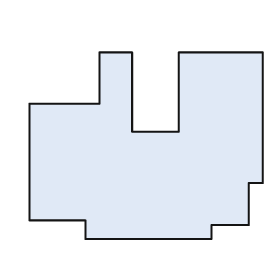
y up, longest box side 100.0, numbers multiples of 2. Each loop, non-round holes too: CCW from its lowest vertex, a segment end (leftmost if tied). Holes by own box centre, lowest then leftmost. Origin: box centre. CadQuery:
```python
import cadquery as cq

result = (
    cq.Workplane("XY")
    .moveTo(-26.0, -40.0)
    .lineTo(28.0, -40.0)
    .lineTo(28.0, -34.0)
    .lineTo(44.0, -34.0)
    .lineTo(44.0, -16.0)
    .lineTo(50.0, -16.0)
    .lineTo(50.0, 40.0)
    .lineTo(14.0, 40.0)
    .lineTo(14.0, 6.0)
    .lineTo(-6.0, 6.0)
    .lineTo(-6.0, 40.0)
    .lineTo(-20.0, 40.0)
    .lineTo(-20.0, 18.0)
    .lineTo(-50.0, 18.0)
    .lineTo(-50.0, -32.0)
    .lineTo(-26.0, -32.0)
    .close()
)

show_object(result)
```